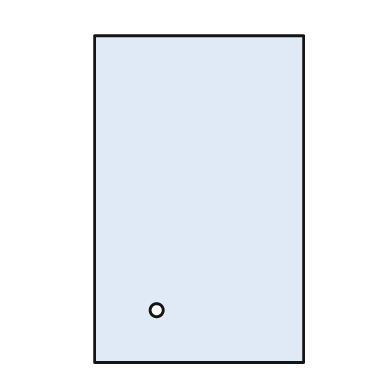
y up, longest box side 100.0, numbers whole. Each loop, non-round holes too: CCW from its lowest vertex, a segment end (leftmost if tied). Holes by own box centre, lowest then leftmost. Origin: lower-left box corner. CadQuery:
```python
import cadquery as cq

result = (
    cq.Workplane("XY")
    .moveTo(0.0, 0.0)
    .lineTo(64.0, 0.0)
    .lineTo(64.0, 100.0)
    .lineTo(0.0, 100.0)
    .close()
    .moveTo(19.0, 16.0)
    .circle(2.0)
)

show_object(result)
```